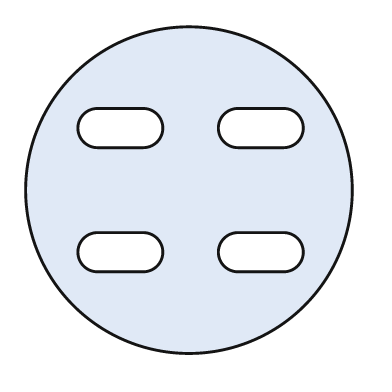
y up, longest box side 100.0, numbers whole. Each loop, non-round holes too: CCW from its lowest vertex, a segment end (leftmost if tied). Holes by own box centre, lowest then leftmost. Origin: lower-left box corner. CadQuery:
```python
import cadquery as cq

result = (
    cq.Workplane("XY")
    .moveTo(50.0, 50.0)
    .circle(50.0)
    .moveTo(22.0, 25.0)
    .lineTo(36.0, 25.0)
    .threePointArc((42.0, 31.0), (36.0, 37.0))
    .lineTo(22.0, 37.0)
    .threePointArc((16.0, 31.0), (22.0, 25.0))
    .close()
    .moveTo(65.0, 25.0)
    .lineTo(79.0, 25.0)
    .threePointArc((85.0, 31.0), (79.0, 37.0))
    .lineTo(65.0, 37.0)
    .threePointArc((59.0, 31.0), (65.0, 25.0))
    .close()
    .moveTo(22.0, 63.0)
    .lineTo(36.0, 63.0)
    .threePointArc((42.0, 69.0), (36.0, 75.0))
    .lineTo(22.0, 75.0)
    .threePointArc((16.0, 69.0), (22.0, 63.0))
    .close()
    .moveTo(65.0, 63.0)
    .lineTo(79.0, 63.0)
    .threePointArc((85.0, 69.0), (79.0, 75.0))
    .lineTo(65.0, 75.0)
    .threePointArc((59.0, 69.0), (65.0, 63.0))
    .close()
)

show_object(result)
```